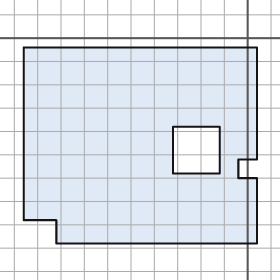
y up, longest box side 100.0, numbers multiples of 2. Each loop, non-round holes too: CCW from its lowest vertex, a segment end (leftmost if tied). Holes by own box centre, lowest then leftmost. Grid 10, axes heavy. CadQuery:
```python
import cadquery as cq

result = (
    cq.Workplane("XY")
    .moveTo(-82.0, -88.0)
    .lineTo(4.0, -88.0)
    .lineTo(4.0, -60.0)
    .lineTo(-4.0, -60.0)
    .lineTo(-4.0, -52.0)
    .lineTo(4.0, -52.0)
    .lineTo(4.0, -4.0)
    .lineTo(-96.0, -4.0)
    .lineTo(-96.0, -78.0)
    .lineTo(-82.0, -78.0)
    .close()
    .moveTo(-32.0, -58.0)
    .lineTo(-12.0, -58.0)
    .lineTo(-12.0, -38.0)
    .lineTo(-32.0, -38.0)
    .close()
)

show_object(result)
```